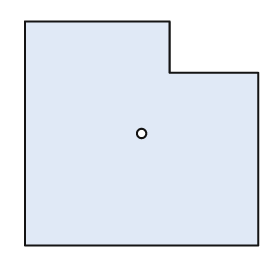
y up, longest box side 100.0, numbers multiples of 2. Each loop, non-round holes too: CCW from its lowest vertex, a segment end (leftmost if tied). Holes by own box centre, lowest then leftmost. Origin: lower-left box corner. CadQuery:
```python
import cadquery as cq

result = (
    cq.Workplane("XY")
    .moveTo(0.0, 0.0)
    .lineTo(100.0, 0.0)
    .lineTo(100.0, 74.0)
    .lineTo(62.0, 74.0)
    .lineTo(62.0, 96.0)
    .lineTo(0.0, 96.0)
    .close()
    .moveTo(50.0, 48.0)
    .circle(2.0)
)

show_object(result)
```